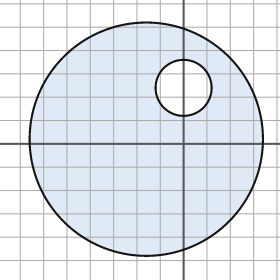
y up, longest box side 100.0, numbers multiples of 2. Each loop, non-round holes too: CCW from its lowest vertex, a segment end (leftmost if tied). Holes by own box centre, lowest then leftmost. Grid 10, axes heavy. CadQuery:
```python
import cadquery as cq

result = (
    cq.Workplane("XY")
    .moveTo(-16.0, 2.0)
    .circle(50.0)
    .moveTo(0.0, 24.0)
    .circle(12.0)
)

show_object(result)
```